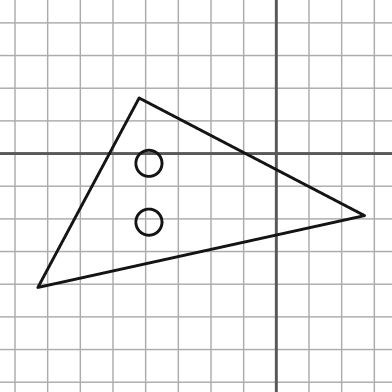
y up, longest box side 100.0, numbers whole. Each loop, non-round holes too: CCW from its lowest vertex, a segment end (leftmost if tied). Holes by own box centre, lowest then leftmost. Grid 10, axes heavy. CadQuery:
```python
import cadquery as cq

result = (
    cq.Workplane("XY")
    .moveTo(-73.0, -41.0)
    .lineTo(27.0, -19.0)
    .lineTo(-42.0, 17.0)
    .close()
    .moveTo(-39.0, -21.0)
    .circle(4.0)
    .moveTo(-39.0, -3.0)
    .circle(4.0)
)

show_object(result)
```